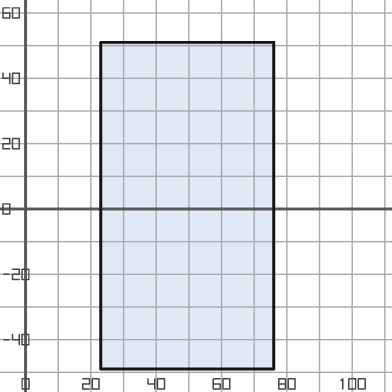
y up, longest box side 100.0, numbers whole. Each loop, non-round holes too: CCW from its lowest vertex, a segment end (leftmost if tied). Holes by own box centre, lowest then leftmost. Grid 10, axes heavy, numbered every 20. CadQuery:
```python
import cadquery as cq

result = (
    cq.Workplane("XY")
    .moveTo(23.0, -49.0)
    .lineTo(76.0, -49.0)
    .lineTo(76.0, 51.0)
    .lineTo(23.0, 51.0)
    .close()
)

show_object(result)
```